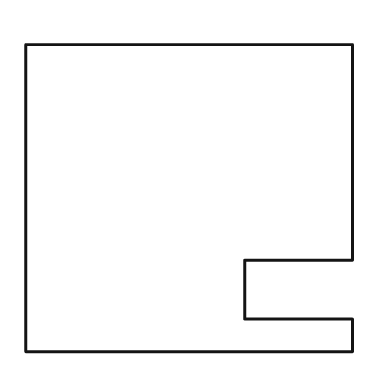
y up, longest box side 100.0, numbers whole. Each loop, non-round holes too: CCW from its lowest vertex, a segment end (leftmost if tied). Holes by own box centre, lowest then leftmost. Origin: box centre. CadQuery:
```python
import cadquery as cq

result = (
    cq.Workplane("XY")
    .moveTo(-50.0, -47.0)
    .lineTo(50.0, -47.0)
    .lineTo(50.0, -37.0)
    .lineTo(17.0, -37.0)
    .lineTo(17.0, -19.0)
    .lineTo(50.0, -19.0)
    .lineTo(50.0, 47.0)
    .lineTo(-50.0, 47.0)
    .close()
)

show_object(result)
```